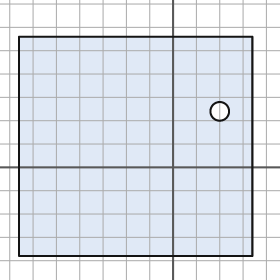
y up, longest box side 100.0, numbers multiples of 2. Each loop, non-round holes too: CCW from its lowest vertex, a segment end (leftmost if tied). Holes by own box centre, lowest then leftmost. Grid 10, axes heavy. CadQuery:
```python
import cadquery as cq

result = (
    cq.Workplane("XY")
    .moveTo(-66.0, -38.0)
    .lineTo(34.0, -38.0)
    .lineTo(34.0, 56.0)
    .lineTo(-66.0, 56.0)
    .close()
    .moveTo(20.0, 24.0)
    .circle(4.0)
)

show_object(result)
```